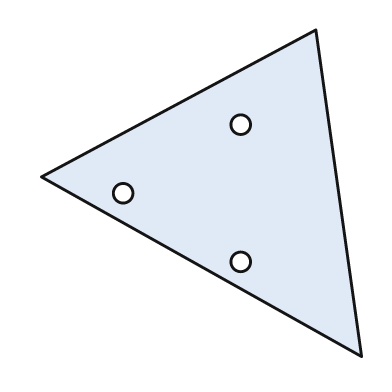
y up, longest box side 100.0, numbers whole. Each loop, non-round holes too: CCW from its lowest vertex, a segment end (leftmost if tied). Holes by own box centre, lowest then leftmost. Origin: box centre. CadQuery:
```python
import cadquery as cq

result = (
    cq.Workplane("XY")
    .moveTo(49.0, -50.0)
    .lineTo(35.0, 50.0)
    .lineTo(-49.0, 5.0)
    .close()
    .moveTo(12.0, -21.0)
    .circle(3.0)
    .moveTo(-24.0, 0.0)
    .circle(3.0)
    .moveTo(12.0, 21.0)
    .circle(3.0)
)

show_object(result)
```